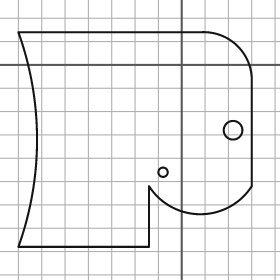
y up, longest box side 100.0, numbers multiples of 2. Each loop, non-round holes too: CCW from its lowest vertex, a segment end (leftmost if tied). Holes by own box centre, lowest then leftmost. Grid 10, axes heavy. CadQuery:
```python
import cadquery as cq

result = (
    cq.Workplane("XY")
    .moveTo(-70.0, -78.0)
    .lineTo(-14.0, -78.0)
    .lineTo(-14.0, -52.0)
    .threePointArc((8.0, -64.0), (30.0, -52.0))
    .lineTo(30.0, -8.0)
    .threePointArc((24.0, 8.0), (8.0, 14.0))
    .lineTo(-70.0, 14.0)
    .threePointArc((-62.0, -32.0), (-70.0, -78.0))
    .close()
    .moveTo(-8.0, -46.0)
    .circle(2.0)
    .moveTo(22.0, -28.0)
    .circle(4.0)
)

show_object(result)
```